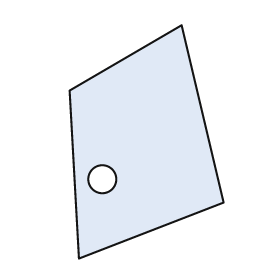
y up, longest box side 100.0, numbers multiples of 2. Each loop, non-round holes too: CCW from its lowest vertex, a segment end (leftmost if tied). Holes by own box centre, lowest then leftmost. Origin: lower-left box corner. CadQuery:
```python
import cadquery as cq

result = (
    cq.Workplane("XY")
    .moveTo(4.0, 0.0)
    .lineTo(66.0, 24.0)
    .lineTo(48.0, 100.0)
    .lineTo(0.0, 72.0)
    .close()
    .moveTo(14.0, 34.0)
    .circle(6.0)
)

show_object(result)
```